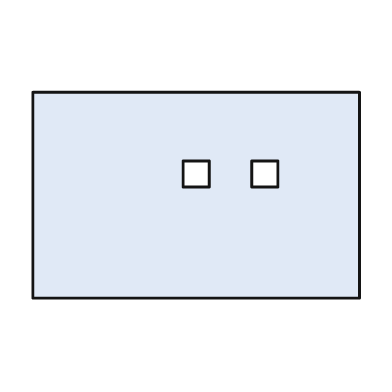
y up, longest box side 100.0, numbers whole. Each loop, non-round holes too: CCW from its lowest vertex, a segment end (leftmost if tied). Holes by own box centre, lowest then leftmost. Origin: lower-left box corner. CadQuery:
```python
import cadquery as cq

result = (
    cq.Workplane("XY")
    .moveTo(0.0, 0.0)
    .lineTo(100.0, 0.0)
    .lineTo(100.0, 63.0)
    .lineTo(0.0, 63.0)
    .close()
    .moveTo(46.0, 34.0)
    .lineTo(54.0, 34.0)
    .lineTo(54.0, 42.0)
    .lineTo(46.0, 42.0)
    .close()
    .moveTo(67.0, 34.0)
    .lineTo(75.0, 34.0)
    .lineTo(75.0, 42.0)
    .lineTo(67.0, 42.0)
    .close()
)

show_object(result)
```